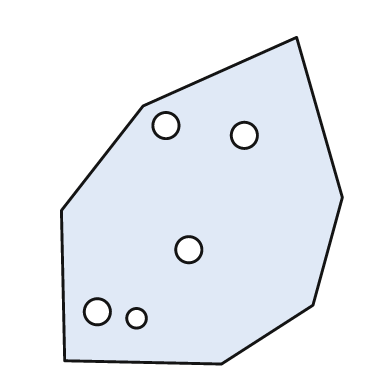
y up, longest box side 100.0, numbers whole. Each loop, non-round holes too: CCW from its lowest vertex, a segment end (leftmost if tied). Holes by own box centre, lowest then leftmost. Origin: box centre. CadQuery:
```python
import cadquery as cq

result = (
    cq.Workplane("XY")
    .moveTo(6.0, -50.0)
    .lineTo(34.0, -32.0)
    .lineTo(43.0, 1.0)
    .lineTo(29.0, 50.0)
    .lineTo(-18.0, 29.0)
    .lineTo(-43.0, -3.0)
    .lineTo(-42.0, -49.0)
    .close()
    .moveTo(-20.0, -36.0)
    .circle(3.0)
    .moveTo(-32.0, -34.0)
    .circle(4.0)
    .moveTo(-4.0, -15.0)
    .circle(4.0)
    .moveTo(13.0, 20.0)
    .circle(4.0)
    .moveTo(-11.0, 23.0)
    .circle(4.0)
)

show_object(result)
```